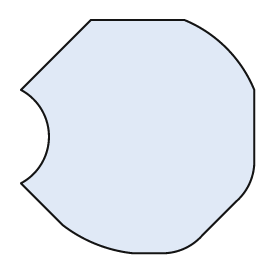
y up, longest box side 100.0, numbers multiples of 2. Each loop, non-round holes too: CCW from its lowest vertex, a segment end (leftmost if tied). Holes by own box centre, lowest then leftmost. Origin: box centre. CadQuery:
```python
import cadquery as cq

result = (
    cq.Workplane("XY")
    .moveTo(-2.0, -50.0)
    .lineTo(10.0, -50.0)
    .threePointArc((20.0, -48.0), (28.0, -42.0))
    .lineTo(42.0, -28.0)
    .threePointArc((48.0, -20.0), (50.0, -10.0))
    .lineTo(50.0, 20.0)
    .threePointArc((38.0, 38.0), (20.0, 50.0))
    .lineTo(-20.0, 50.0)
    .lineTo(-50.0, 20.0)
    .threePointArc((-38.0, 0.0), (-50.0, -20.0))
    .lineTo(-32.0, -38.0)
    .threePointArc((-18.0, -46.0), (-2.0, -50.0))
    .close()
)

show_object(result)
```